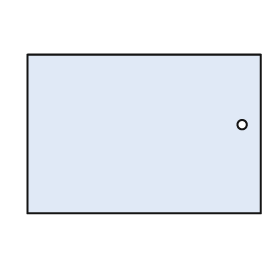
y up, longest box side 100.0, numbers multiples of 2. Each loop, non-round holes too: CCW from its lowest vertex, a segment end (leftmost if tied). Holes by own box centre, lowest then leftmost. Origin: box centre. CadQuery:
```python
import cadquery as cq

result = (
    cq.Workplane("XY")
    .moveTo(-50.0, -34.0)
    .lineTo(50.0, -34.0)
    .lineTo(50.0, 34.0)
    .lineTo(-50.0, 34.0)
    .close()
    .moveTo(42.0, 4.0)
    .circle(2.0)
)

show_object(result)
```